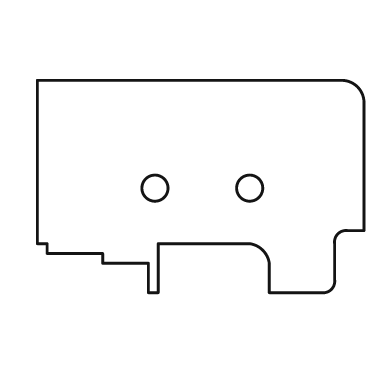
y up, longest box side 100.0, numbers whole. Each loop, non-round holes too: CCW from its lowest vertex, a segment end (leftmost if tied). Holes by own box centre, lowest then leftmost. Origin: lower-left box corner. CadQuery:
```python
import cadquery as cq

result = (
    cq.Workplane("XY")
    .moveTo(34.0, 0.0)
    .lineTo(37.0, 0.0)
    .lineTo(37.0, 15.0)
    .lineTo(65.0, 15.0)
    .threePointArc((69.0, 13.0), (71.0, 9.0))
    .lineTo(71.0, 0.0)
    .lineTo(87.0, 0.0)
    .threePointArc((90.0, 1.0), (91.0, 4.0))
    .lineTo(91.0, 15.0)
    .threePointArc((92.0, 18.0), (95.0, 19.0))
    .lineTo(100.0, 19.0)
    .lineTo(100.0, 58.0)
    .threePointArc((98.0, 63.0), (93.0, 65.0))
    .lineTo(0.0, 65.0)
    .lineTo(0.0, 15.0)
    .lineTo(3.0, 15.0)
    .lineTo(3.0, 12.0)
    .lineTo(20.0, 12.0)
    .lineTo(20.0, 9.0)
    .lineTo(34.0, 9.0)
    .close()
    .moveTo(36.0, 32.0)
    .circle(4.0)
    .moveTo(65.0, 32.0)
    .circle(4.0)
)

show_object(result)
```